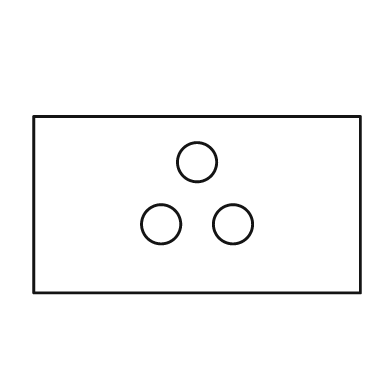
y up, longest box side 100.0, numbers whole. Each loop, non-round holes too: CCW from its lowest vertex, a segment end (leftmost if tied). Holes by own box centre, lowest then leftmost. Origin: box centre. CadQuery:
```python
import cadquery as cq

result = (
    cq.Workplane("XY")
    .moveTo(-50.0, -27.0)
    .lineTo(50.0, -27.0)
    .lineTo(50.0, 27.0)
    .lineTo(-50.0, 27.0)
    .close()
    .moveTo(-11.0, -6.0)
    .circle(6.0)
    .moveTo(11.0, -6.0)
    .circle(6.0)
    .moveTo(0.0, 13.0)
    .circle(6.0)
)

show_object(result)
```